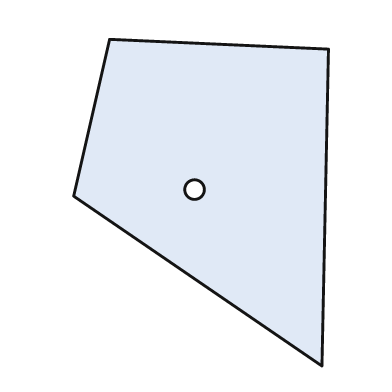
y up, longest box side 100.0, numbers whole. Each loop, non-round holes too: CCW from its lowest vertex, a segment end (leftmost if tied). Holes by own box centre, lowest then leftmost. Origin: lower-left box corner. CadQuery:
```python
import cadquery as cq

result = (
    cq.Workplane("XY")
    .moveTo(76.0, 0.0)
    .lineTo(78.0, 97.0)
    .lineTo(11.0, 100.0)
    .lineTo(0.0, 52.0)
    .close()
    .moveTo(37.0, 54.0)
    .circle(3.0)
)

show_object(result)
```